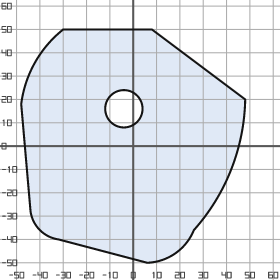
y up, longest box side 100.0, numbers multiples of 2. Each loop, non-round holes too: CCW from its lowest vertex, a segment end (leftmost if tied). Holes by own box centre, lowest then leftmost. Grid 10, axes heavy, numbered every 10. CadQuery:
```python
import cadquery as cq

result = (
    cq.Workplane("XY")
    .moveTo(6.0, -50.0)
    .threePointArc((18.0, -46.0), (26.0, -36.0))
    .threePointArc((42.0, -10.0), (48.0, 20.0))
    .lineTo(8.0, 50.0)
    .lineTo(-30.0, 50.0)
    .threePointArc((-42.0, 36.0), (-48.0, 18.0))
    .lineTo(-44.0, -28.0)
    .threePointArc((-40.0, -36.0), (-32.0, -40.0))
    .close()
    .moveTo(-4.0, 16.0)
    .circle(8.0)
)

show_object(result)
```